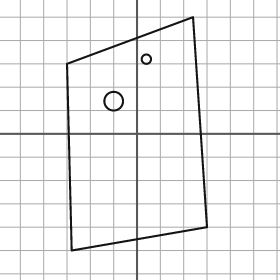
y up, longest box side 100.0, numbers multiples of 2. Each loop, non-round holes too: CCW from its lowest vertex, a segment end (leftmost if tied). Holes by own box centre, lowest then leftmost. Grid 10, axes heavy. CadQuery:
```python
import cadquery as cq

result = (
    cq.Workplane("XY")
    .moveTo(-28.0, -50.0)
    .lineTo(30.0, -40.0)
    .lineTo(24.0, 50.0)
    .lineTo(-30.0, 30.0)
    .close()
    .moveTo(-10.0, 14.0)
    .circle(4.0)
    .moveTo(4.0, 32.0)
    .circle(2.0)
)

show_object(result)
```